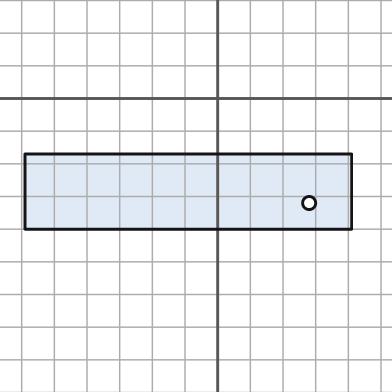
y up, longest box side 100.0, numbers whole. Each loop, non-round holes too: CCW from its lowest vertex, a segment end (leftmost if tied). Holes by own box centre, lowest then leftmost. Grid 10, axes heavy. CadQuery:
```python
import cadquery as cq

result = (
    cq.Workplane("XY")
    .moveTo(-59.0, -40.0)
    .lineTo(41.0, -40.0)
    .lineTo(41.0, -17.0)
    .lineTo(-59.0, -17.0)
    .close()
    .moveTo(28.0, -32.0)
    .circle(2.0)
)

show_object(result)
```